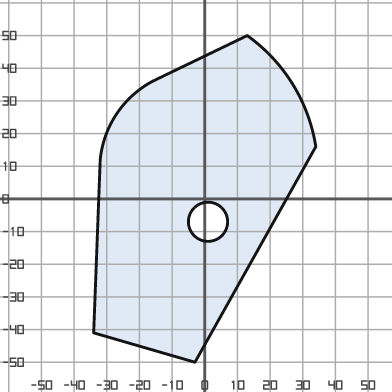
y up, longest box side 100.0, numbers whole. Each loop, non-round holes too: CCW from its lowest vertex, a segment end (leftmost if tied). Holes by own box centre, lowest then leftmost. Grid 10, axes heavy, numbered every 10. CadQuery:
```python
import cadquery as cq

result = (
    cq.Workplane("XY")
    .moveTo(-3.0, -50.0)
    .lineTo(34.0, 16.0)
    .threePointArc((27.0, 35.0), (13.0, 50.0))
    .lineTo(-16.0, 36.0)
    .threePointArc((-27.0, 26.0), (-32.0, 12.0))
    .lineTo(-34.0, -41.0)
    .close()
    .moveTo(1.0, -7.0)
    .circle(6.0)
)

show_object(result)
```